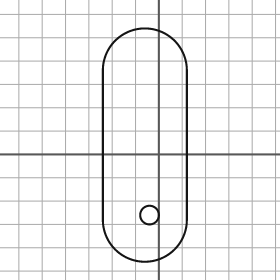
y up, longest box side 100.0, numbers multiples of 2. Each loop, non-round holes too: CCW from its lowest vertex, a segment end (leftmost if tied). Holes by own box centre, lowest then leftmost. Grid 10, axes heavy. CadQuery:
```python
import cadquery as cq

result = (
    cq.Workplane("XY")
    .moveTo(-24.0, -28.0)
    .threePointArc((-6.0, -46.0), (12.0, -28.0))
    .lineTo(12.0, 36.0)
    .threePointArc((-6.0, 54.0), (-24.0, 36.0))
    .close()
    .moveTo(-4.0, -26.0)
    .circle(4.0)
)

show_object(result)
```